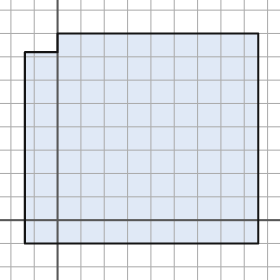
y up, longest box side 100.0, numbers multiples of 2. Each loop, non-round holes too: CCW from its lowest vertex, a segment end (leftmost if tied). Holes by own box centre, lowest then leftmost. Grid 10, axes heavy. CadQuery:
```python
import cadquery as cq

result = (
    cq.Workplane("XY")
    .moveTo(-14.0, -10.0)
    .lineTo(86.0, -10.0)
    .lineTo(86.0, 80.0)
    .lineTo(0.0, 80.0)
    .lineTo(0.0, 72.0)
    .lineTo(-14.0, 72.0)
    .close()
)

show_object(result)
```